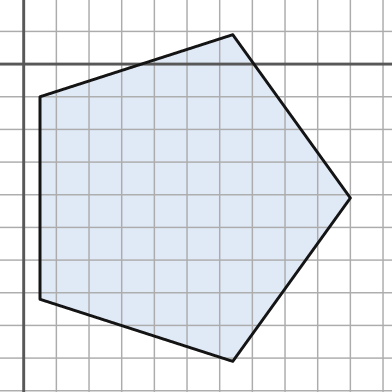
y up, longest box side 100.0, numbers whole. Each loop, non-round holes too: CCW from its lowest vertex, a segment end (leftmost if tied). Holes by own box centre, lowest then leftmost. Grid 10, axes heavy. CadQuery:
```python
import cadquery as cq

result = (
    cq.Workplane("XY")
    .moveTo(64.0, -91.0)
    .lineTo(100.0, -41.0)
    .lineTo(64.0, 9.0)
    .lineTo(5.0, -10.0)
    .lineTo(5.0, -72.0)
    .close()
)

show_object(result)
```